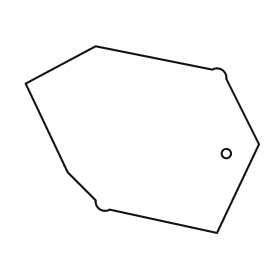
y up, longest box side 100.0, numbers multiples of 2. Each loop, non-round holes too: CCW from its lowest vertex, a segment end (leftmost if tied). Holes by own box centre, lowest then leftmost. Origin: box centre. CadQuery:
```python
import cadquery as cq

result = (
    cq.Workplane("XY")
    .moveTo(32.0, -40.0)
    .lineTo(50.0, -2.0)
    .lineTo(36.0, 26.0)
    .threePointArc((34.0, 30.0), (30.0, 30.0))
    .lineTo(-20.0, 40.0)
    .lineTo(-50.0, 24.0)
    .lineTo(-32.0, -14.0)
    .lineTo(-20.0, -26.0)
    .threePointArc((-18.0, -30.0), (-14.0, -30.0))
    .close()
    .moveTo(36.0, -6.0)
    .circle(2.0)
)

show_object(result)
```